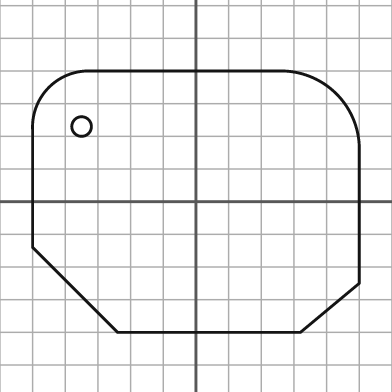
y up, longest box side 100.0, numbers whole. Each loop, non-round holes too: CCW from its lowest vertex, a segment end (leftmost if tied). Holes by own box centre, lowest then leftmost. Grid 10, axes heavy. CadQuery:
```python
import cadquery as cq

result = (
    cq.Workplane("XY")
    .moveTo(-24.0, -40.0)
    .lineTo(32.0, -40.0)
    .lineTo(50.0, -25.0)
    .lineTo(50.0, 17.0)
    .threePointArc((43.0, 33.0), (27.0, 40.0))
    .lineTo(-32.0, 40.0)
    .threePointArc((-45.0, 35.0), (-50.0, 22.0))
    .lineTo(-50.0, -14.0)
    .close()
    .moveTo(-35.0, 23.0)
    .circle(3.0)
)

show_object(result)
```